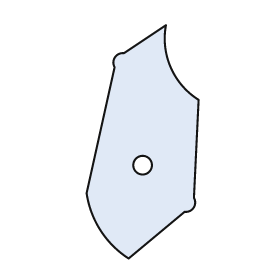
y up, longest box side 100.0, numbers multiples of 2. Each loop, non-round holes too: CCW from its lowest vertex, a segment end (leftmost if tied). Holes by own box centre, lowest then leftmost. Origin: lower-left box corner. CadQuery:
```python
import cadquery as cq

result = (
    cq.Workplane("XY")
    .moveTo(18.0, 0.0)
    .lineTo(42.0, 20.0)
    .threePointArc((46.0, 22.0), (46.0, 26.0))
    .lineTo(48.0, 68.0)
    .threePointArc((36.0, 82.0), (34.0, 100.0))
    .lineTo(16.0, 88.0)
    .threePointArc((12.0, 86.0), (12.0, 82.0))
    .lineTo(0.0, 28.0)
    .threePointArc((6.0, 12.0), (18.0, 0.0))
    .close()
    .moveTo(24.0, 40.0)
    .circle(4.0)
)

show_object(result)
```